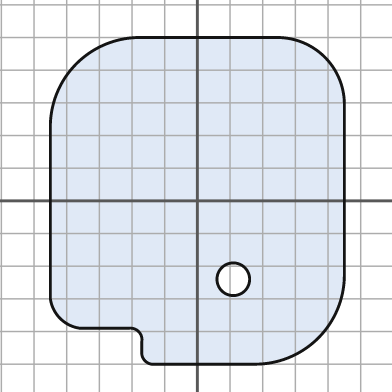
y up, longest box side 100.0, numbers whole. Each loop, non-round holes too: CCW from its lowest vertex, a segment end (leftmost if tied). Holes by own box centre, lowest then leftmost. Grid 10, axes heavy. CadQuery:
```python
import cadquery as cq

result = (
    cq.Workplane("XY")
    .moveTo(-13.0, -50.0)
    .lineTo(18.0, -50.0)
    .threePointArc((37.0, -42.0), (45.0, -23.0))
    .lineTo(45.0, 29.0)
    .threePointArc((39.0, 44.0), (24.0, 50.0))
    .lineTo(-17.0, 50.0)
    .threePointArc((-37.0, 42.0), (-45.0, 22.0))
    .lineTo(-45.0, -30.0)
    .threePointArc((-42.0, -36.0), (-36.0, -39.0))
    .lineTo(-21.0, -39.0)
    .threePointArc((-18.0, -40.0), (-17.0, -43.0))
    .lineTo(-17.0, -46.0)
    .threePointArc((-16.0, -49.0), (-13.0, -50.0))
    .close()
    .moveTo(11.0, -24.0)
    .circle(5.0)
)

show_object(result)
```